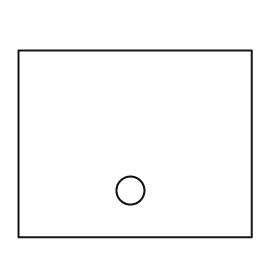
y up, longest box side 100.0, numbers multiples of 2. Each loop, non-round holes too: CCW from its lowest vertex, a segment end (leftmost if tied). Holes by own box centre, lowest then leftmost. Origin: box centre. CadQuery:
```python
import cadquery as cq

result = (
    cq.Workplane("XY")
    .moveTo(-50.0, -40.0)
    .lineTo(50.0, -40.0)
    .lineTo(50.0, 40.0)
    .lineTo(-50.0, 40.0)
    .close()
    .moveTo(-2.0, -20.0)
    .circle(6.0)
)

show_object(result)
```